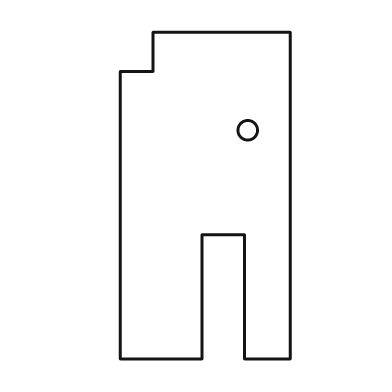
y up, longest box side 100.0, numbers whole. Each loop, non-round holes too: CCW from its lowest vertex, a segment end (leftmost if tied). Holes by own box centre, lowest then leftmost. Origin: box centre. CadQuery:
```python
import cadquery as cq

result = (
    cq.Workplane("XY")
    .moveTo(-26.0, -50.0)
    .lineTo(-1.0, -50.0)
    .lineTo(-1.0, -12.0)
    .lineTo(12.0, -12.0)
    .lineTo(12.0, -50.0)
    .lineTo(26.0, -50.0)
    .lineTo(26.0, 50.0)
    .lineTo(-16.0, 50.0)
    .lineTo(-16.0, 38.0)
    .lineTo(-26.0, 38.0)
    .close()
    .moveTo(13.0, 20.0)
    .circle(3.0)
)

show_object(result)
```